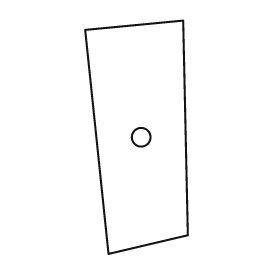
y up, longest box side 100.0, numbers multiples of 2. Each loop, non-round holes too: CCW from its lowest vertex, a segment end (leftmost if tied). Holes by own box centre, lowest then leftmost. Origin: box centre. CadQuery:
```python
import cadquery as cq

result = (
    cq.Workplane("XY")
    .moveTo(-12.0, -50.0)
    .lineTo(22.0, -42.0)
    .lineTo(20.0, 50.0)
    .lineTo(-22.0, 46.0)
    .close()
    .moveTo(2.0, 0.0)
    .circle(4.0)
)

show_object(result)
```